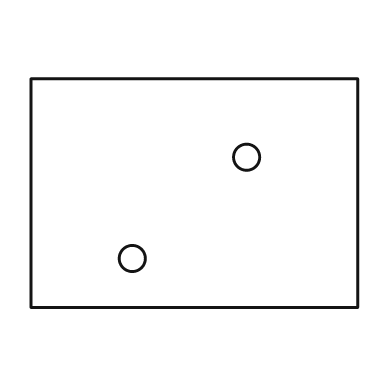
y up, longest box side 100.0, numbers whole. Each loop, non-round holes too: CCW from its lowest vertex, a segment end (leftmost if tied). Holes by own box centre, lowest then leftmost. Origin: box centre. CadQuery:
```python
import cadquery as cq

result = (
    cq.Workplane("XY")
    .moveTo(-50.0, -35.0)
    .lineTo(50.0, -35.0)
    .lineTo(50.0, 35.0)
    .lineTo(-50.0, 35.0)
    .close()
    .moveTo(-19.0, -20.0)
    .circle(4.0)
    .moveTo(16.0, 11.0)
    .circle(4.0)
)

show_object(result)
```